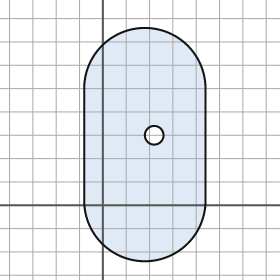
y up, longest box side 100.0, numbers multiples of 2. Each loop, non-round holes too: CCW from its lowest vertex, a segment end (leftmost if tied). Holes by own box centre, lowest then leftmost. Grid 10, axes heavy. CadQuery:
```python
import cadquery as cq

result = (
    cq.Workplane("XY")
    .moveTo(-8.0, 2.0)
    .threePointArc((18.0, -24.0), (44.0, 2.0))
    .lineTo(44.0, 50.0)
    .threePointArc((18.0, 76.0), (-8.0, 50.0))
    .close()
    .moveTo(22.0, 30.0)
    .circle(4.0)
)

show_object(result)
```